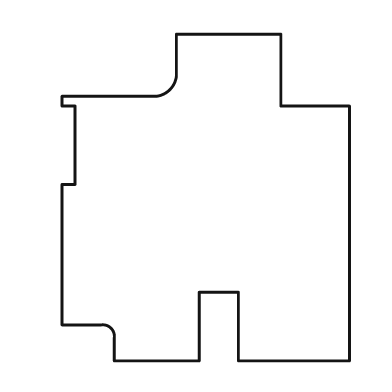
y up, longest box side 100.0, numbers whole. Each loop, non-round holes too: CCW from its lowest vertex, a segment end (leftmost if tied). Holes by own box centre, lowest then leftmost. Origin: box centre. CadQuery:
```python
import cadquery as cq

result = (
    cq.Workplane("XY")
    .moveTo(-28.0, -50.0)
    .lineTo(-2.0, -50.0)
    .lineTo(-2.0, -29.0)
    .lineTo(10.0, -29.0)
    .lineTo(10.0, -50.0)
    .lineTo(44.0, -50.0)
    .lineTo(44.0, 28.0)
    .lineTo(23.0, 28.0)
    .lineTo(23.0, 50.0)
    .lineTo(-9.0, 50.0)
    .lineTo(-9.0, 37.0)
    .threePointArc((-11.0, 33.0), (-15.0, 31.0))
    .lineTo(-44.0, 31.0)
    .lineTo(-44.0, 28.0)
    .lineTo(-40.0, 28.0)
    .lineTo(-40.0, 4.0)
    .lineTo(-44.0, 4.0)
    .lineTo(-44.0, -39.0)
    .lineTo(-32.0, -39.0)
    .threePointArc((-29.0, -40.0), (-28.0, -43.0))
    .close()
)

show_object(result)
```